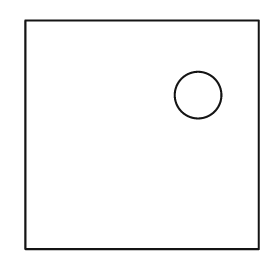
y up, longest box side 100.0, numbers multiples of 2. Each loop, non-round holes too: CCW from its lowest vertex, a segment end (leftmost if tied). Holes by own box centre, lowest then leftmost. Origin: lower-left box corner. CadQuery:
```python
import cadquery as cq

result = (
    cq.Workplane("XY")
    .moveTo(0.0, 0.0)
    .lineTo(100.0, 0.0)
    .lineTo(100.0, 98.0)
    .lineTo(0.0, 98.0)
    .close()
    .moveTo(74.0, 66.0)
    .circle(10.0)
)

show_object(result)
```